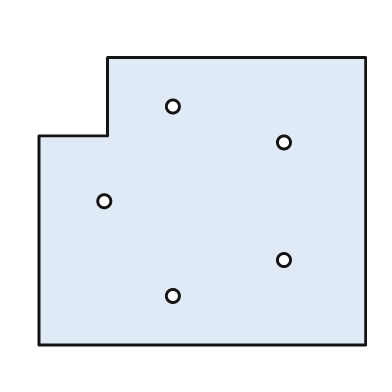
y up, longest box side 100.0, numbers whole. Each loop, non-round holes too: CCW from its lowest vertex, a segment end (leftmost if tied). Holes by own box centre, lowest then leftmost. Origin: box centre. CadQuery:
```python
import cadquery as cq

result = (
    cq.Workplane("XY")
    .moveTo(-50.0, -44.0)
    .lineTo(50.0, -44.0)
    .lineTo(50.0, 44.0)
    .lineTo(-29.0, 44.0)
    .lineTo(-29.0, 20.0)
    .lineTo(-50.0, 20.0)
    .close()
    .moveTo(-9.0, -29.0)
    .circle(2.0)
    .moveTo(25.0, -18.0)
    .circle(2.0)
    .moveTo(-30.0, 0.0)
    .circle(2.0)
    .moveTo(25.0, 18.0)
    .circle(2.0)
    .moveTo(-9.0, 29.0)
    .circle(2.0)
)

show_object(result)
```